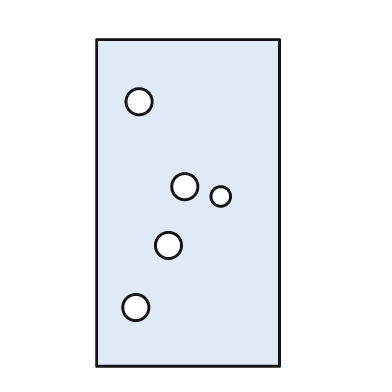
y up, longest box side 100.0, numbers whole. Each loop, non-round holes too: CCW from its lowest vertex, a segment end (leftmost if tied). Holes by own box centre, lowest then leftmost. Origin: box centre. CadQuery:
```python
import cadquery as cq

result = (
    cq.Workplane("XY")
    .moveTo(-28.0, -50.0)
    .lineTo(28.0, -50.0)
    .lineTo(28.0, 50.0)
    .lineTo(-28.0, 50.0)
    .close()
    .moveTo(-16.0, -32.0)
    .circle(4.0)
    .moveTo(-6.0, -13.0)
    .circle(4.0)
    .moveTo(10.0, 2.0)
    .circle(3.0)
    .moveTo(-1.0, 5.0)
    .circle(4.0)
    .moveTo(-15.0, 31.0)
    .circle(4.0)
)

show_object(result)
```